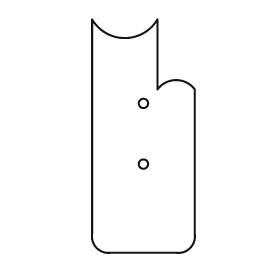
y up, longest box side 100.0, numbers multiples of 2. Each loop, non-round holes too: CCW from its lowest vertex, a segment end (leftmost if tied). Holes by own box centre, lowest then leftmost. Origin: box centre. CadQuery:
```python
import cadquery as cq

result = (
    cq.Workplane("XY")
    .moveTo(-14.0, -50.0)
    .lineTo(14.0, -50.0)
    .threePointArc((20.0, -48.0), (22.0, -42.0))
    .lineTo(22.0, 20.0)
    .threePointArc((14.0, 24.0), (6.0, 20.0))
    .lineTo(6.0, 50.0)
    .threePointArc((-8.0, 42.0), (-22.0, 50.0))
    .lineTo(-22.0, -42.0)
    .threePointArc((-20.0, -48.0), (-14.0, -50.0))
    .close()
    .moveTo(0.0, -12.0)
    .circle(2.0)
    .moveTo(0.0, 14.0)
    .circle(2.0)
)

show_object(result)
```